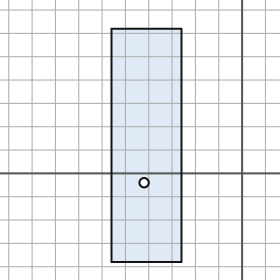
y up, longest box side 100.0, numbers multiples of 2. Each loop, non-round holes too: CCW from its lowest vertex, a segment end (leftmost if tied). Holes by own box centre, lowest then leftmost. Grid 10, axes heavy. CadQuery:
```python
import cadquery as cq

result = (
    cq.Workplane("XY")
    .moveTo(-56.0, -38.0)
    .lineTo(-26.0, -38.0)
    .lineTo(-26.0, 62.0)
    .lineTo(-56.0, 62.0)
    .close()
    .moveTo(-42.0, -4.0)
    .circle(2.0)
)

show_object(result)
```